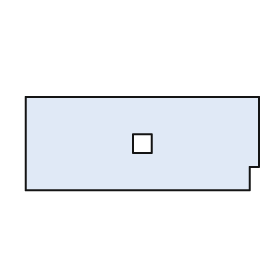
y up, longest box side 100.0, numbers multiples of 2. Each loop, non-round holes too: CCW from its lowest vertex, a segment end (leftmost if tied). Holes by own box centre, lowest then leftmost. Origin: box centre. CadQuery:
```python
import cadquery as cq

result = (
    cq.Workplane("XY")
    .moveTo(-50.0, -20.0)
    .lineTo(46.0, -20.0)
    .lineTo(46.0, -10.0)
    .lineTo(50.0, -10.0)
    .lineTo(50.0, 20.0)
    .lineTo(-50.0, 20.0)
    .close()
    .moveTo(-4.0, -4.0)
    .lineTo(4.0, -4.0)
    .lineTo(4.0, 4.0)
    .lineTo(-4.0, 4.0)
    .close()
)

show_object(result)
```